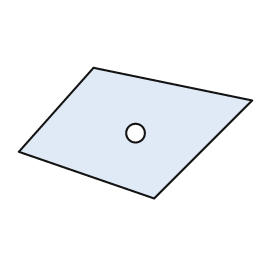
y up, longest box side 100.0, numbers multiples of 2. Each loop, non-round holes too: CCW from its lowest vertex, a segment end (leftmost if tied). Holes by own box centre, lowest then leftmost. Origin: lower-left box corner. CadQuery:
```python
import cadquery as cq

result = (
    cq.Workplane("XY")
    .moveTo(58.0, 0.0)
    .lineTo(100.0, 42.0)
    .lineTo(32.0, 56.0)
    .lineTo(0.0, 20.0)
    .close()
    .moveTo(50.0, 28.0)
    .circle(4.0)
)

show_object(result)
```